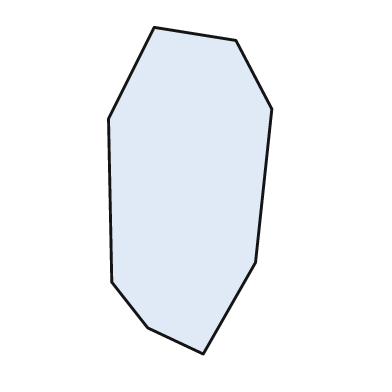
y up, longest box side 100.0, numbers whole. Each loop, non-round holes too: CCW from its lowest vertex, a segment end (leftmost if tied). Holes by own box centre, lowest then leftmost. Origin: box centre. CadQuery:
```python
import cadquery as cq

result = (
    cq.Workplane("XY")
    .moveTo(4.0, -50.0)
    .lineTo(20.0, -22.0)
    .lineTo(25.0, 25.0)
    .lineTo(14.0, 46.0)
    .lineTo(-11.0, 50.0)
    .lineTo(-25.0, 22.0)
    .lineTo(-24.0, -28.0)
    .lineTo(-13.0, -42.0)
    .close()
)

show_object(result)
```